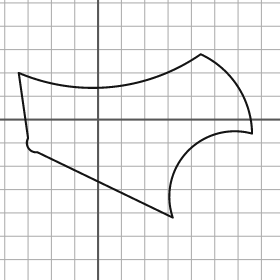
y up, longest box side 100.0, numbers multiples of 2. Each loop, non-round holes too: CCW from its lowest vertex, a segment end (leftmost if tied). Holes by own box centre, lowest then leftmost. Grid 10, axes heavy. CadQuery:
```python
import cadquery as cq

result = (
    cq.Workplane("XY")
    .moveTo(32.0, -42.0)
    .threePointArc((38.0, -14.0), (66.0, -6.0))
    .threePointArc((60.0, 14.0), (44.0, 28.0))
    .threePointArc((6.0, 14.0), (-34.0, 20.0))
    .lineTo(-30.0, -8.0)
    .threePointArc((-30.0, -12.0), (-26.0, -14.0))
    .close()
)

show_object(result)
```